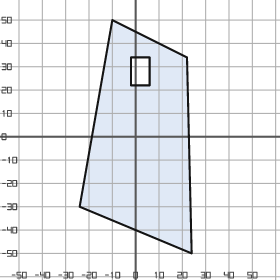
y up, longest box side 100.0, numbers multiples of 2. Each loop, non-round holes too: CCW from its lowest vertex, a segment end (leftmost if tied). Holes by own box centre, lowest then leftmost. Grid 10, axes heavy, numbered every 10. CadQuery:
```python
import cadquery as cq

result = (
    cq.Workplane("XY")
    .moveTo(24.0, -50.0)
    .lineTo(22.0, 34.0)
    .lineTo(-10.0, 50.0)
    .lineTo(-24.0, -30.0)
    .close()
    .moveTo(-2.0, 22.0)
    .lineTo(6.0, 22.0)
    .lineTo(6.0, 34.0)
    .lineTo(-2.0, 34.0)
    .close()
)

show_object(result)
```